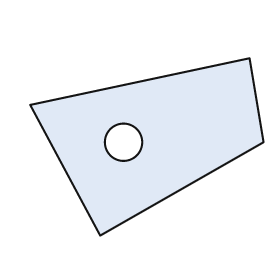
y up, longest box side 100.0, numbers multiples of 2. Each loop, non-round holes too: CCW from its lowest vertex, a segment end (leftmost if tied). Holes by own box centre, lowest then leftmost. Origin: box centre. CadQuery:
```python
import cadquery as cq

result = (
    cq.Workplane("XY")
    .moveTo(-20.0, -38.0)
    .lineTo(50.0, 2.0)
    .lineTo(44.0, 38.0)
    .lineTo(-50.0, 18.0)
    .close()
    .moveTo(-10.0, 2.0)
    .circle(8.0)
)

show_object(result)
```